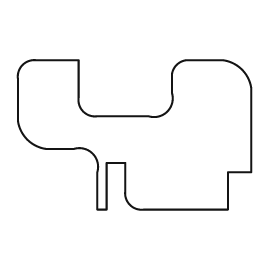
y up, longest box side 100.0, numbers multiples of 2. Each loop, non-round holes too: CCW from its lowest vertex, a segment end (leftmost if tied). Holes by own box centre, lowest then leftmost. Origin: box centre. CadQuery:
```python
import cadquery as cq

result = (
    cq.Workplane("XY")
    .moveTo(-16.0, -32.0)
    .lineTo(-12.0, -32.0)
    .lineTo(-12.0, -12.0)
    .lineTo(-4.0, -12.0)
    .lineTo(-4.0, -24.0)
    .threePointArc((-2.0, -30.0), (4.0, -32.0))
    .lineTo(40.0, -32.0)
    .lineTo(40.0, -16.0)
    .lineTo(50.0, -16.0)
    .lineTo(50.0, 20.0)
    .threePointArc((46.0, 28.0), (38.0, 32.0))
    .lineTo(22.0, 32.0)
    .threePointArc((18.0, 30.0), (16.0, 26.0))
    .lineTo(16.0, 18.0)
    .threePointArc((14.0, 10.0), (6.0, 8.0))
    .lineTo(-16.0, 8.0)
    .threePointArc((-22.0, 10.0), (-24.0, 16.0))
    .lineTo(-24.0, 32.0)
    .lineTo(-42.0, 32.0)
    .threePointArc((-48.0, 30.0), (-50.0, 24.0))
    .lineTo(-50.0, 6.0)
    .threePointArc((-46.0, -2.0), (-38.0, -6.0))
    .lineTo(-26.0, -6.0)
    .threePointArc((-18.0, -8.0), (-16.0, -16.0))
    .close()
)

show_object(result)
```